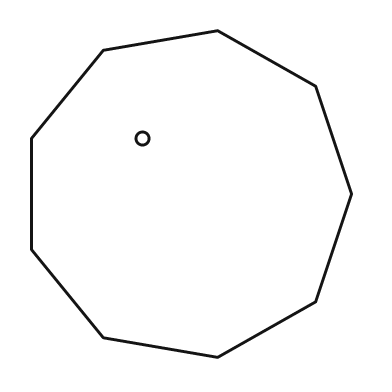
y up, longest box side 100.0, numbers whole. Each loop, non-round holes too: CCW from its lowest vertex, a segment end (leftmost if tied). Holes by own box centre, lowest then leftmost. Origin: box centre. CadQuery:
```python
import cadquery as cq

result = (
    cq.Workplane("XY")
    .moveTo(8.0, -50.0)
    .lineTo(38.0, -33.0)
    .lineTo(49.0, 0.0)
    .lineTo(38.0, 33.0)
    .lineTo(8.0, 50.0)
    .lineTo(-27.0, 44.0)
    .lineTo(-49.0, 17.0)
    .lineTo(-49.0, -17.0)
    .lineTo(-27.0, -44.0)
    .close()
    .moveTo(-15.0, 17.0)
    .circle(2.0)
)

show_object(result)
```